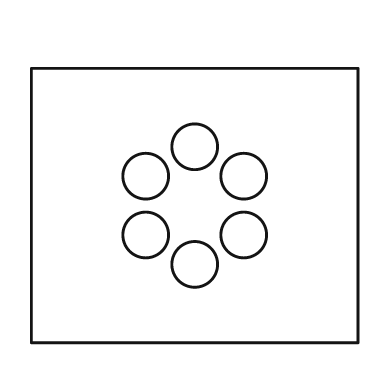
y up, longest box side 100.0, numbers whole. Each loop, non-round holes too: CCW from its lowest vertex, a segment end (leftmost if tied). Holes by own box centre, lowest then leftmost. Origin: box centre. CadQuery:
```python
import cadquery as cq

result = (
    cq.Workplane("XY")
    .moveTo(-50.0, -42.0)
    .lineTo(50.0, -42.0)
    .lineTo(50.0, 42.0)
    .lineTo(-50.0, 42.0)
    .close()
    .moveTo(0.0, -18.0)
    .circle(7.0)
    .moveTo(-15.0, -9.0)
    .circle(7.0)
    .moveTo(15.0, -9.0)
    .circle(7.0)
    .moveTo(-15.0, 9.0)
    .circle(7.0)
    .moveTo(15.0, 9.0)
    .circle(7.0)
    .moveTo(0.0, 18.0)
    .circle(7.0)
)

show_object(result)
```